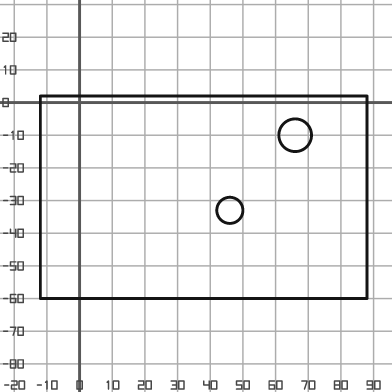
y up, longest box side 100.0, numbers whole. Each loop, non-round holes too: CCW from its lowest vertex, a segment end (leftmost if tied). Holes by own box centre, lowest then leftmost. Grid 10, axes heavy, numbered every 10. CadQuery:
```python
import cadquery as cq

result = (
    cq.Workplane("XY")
    .moveTo(-12.0, -60.0)
    .lineTo(88.0, -60.0)
    .lineTo(88.0, 2.0)
    .lineTo(-12.0, 2.0)
    .close()
    .moveTo(46.0, -33.0)
    .circle(4.0)
    .moveTo(66.0, -10.0)
    .circle(5.0)
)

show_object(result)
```